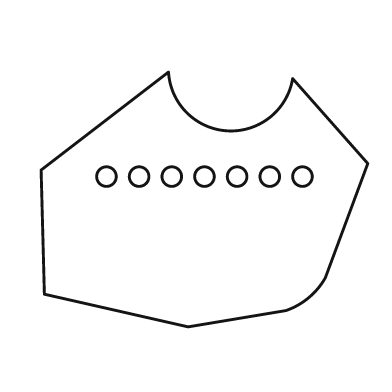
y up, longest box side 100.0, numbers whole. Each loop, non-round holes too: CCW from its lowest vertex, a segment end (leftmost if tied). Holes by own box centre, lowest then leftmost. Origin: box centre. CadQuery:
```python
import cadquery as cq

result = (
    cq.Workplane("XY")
    .moveTo(-5.0, -39.0)
    .lineTo(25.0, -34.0)
    .threePointArc((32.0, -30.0), (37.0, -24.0))
    .lineTo(50.0, 11.0)
    .lineTo(27.0, 37.0)
    .threePointArc((7.0, 21.0), (-11.0, 39.0))
    .lineTo(-50.0, 9.0)
    .lineTo(-49.0, -29.0)
    .close()
    .moveTo(-30.0, 7.0)
    .circle(3.0)
    .moveTo(-20.0, 7.0)
    .circle(3.0)
    .moveTo(-10.0, 7.0)
    .circle(3.0)
    .moveTo(0.0, 7.0)
    .circle(3.0)
    .moveTo(10.0, 7.0)
    .circle(3.0)
    .moveTo(20.0, 7.0)
    .circle(3.0)
    .moveTo(30.0, 7.0)
    .circle(3.0)
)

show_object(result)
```